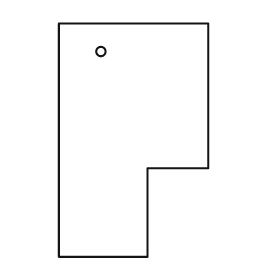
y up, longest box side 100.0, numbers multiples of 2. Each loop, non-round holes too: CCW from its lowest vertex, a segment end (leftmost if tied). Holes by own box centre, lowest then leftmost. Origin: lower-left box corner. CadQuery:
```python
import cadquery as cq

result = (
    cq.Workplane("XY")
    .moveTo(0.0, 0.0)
    .lineTo(38.0, 0.0)
    .lineTo(38.0, 38.0)
    .lineTo(64.0, 38.0)
    .lineTo(64.0, 100.0)
    .lineTo(0.0, 100.0)
    .close()
    .moveTo(18.0, 88.0)
    .circle(2.0)
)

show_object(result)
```